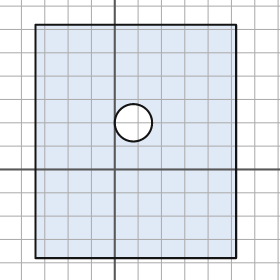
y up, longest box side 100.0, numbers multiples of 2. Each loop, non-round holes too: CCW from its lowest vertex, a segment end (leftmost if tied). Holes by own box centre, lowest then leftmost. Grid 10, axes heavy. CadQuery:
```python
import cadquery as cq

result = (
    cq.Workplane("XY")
    .moveTo(-34.0, -38.0)
    .lineTo(52.0, -38.0)
    .lineTo(52.0, 62.0)
    .lineTo(-34.0, 62.0)
    .close()
    .moveTo(8.0, 20.0)
    .circle(8.0)
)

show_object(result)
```